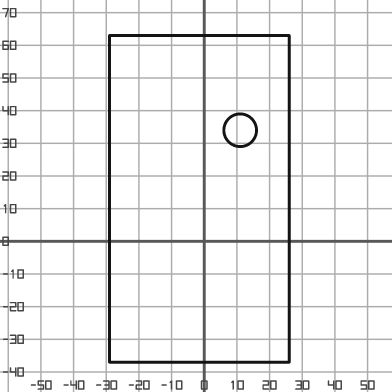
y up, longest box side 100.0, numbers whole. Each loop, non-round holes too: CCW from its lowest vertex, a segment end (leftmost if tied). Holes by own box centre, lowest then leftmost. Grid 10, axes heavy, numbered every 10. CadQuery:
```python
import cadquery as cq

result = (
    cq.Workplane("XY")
    .moveTo(-29.0, -37.0)
    .lineTo(26.0, -37.0)
    .lineTo(26.0, 63.0)
    .lineTo(-29.0, 63.0)
    .close()
    .moveTo(11.0, 34.0)
    .circle(5.0)
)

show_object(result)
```